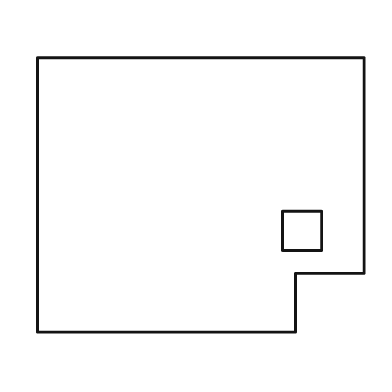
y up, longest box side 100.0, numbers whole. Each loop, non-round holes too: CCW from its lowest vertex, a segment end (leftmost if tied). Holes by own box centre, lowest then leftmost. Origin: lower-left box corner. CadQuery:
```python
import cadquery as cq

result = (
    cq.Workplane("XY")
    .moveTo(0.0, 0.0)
    .lineTo(79.0, 0.0)
    .lineTo(79.0, 18.0)
    .lineTo(100.0, 18.0)
    .lineTo(100.0, 84.0)
    .lineTo(0.0, 84.0)
    .close()
    .moveTo(75.0, 25.0)
    .lineTo(87.0, 25.0)
    .lineTo(87.0, 37.0)
    .lineTo(75.0, 37.0)
    .close()
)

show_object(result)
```